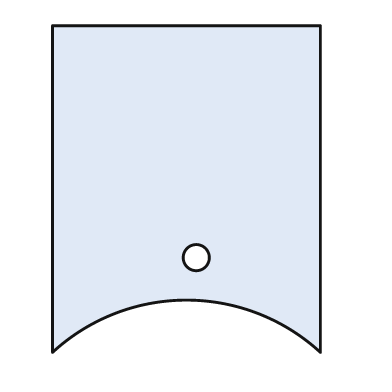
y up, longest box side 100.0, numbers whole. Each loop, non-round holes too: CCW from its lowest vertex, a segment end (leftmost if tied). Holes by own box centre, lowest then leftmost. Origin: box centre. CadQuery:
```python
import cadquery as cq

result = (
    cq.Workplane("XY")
    .moveTo(-41.0, -50.0)
    .threePointArc((0.0, -34.0), (41.0, -50.0))
    .lineTo(41.0, 50.0)
    .lineTo(-41.0, 50.0)
    .close()
    .moveTo(3.0, -21.0)
    .circle(4.0)
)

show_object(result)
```